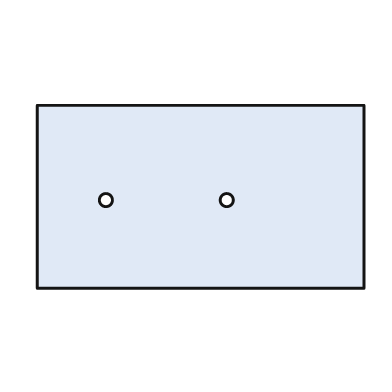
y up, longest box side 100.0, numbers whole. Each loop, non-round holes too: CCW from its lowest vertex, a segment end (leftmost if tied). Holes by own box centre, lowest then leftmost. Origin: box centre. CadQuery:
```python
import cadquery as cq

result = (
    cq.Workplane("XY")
    .moveTo(-50.0, -28.0)
    .lineTo(50.0, -28.0)
    .lineTo(50.0, 28.0)
    .lineTo(-50.0, 28.0)
    .close()
    .moveTo(-29.0, -1.0)
    .circle(2.0)
    .moveTo(8.0, -1.0)
    .circle(2.0)
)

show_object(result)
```